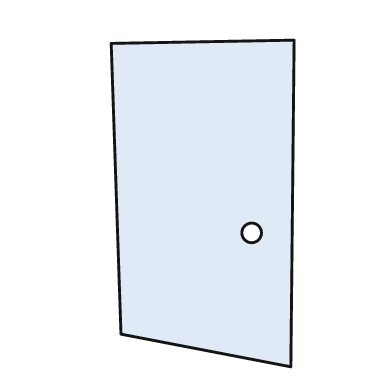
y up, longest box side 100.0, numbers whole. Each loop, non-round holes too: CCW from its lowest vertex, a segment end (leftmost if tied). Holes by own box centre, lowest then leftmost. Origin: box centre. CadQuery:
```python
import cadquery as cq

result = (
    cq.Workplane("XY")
    .moveTo(27.0, -50.0)
    .lineTo(28.0, 50.0)
    .lineTo(-28.0, 49.0)
    .lineTo(-25.0, -40.0)
    .close()
    .moveTo(15.0, -9.0)
    .circle(3.0)
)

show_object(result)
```